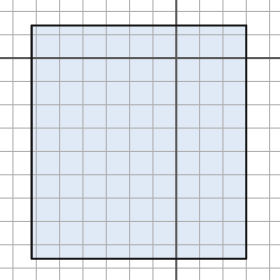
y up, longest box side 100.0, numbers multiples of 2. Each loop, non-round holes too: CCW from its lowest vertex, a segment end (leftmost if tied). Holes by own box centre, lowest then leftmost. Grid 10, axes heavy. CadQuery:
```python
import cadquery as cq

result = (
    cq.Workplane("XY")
    .moveTo(-62.0, -86.0)
    .lineTo(30.0, -86.0)
    .lineTo(30.0, 14.0)
    .lineTo(-62.0, 14.0)
    .close()
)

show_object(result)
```